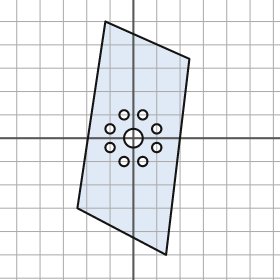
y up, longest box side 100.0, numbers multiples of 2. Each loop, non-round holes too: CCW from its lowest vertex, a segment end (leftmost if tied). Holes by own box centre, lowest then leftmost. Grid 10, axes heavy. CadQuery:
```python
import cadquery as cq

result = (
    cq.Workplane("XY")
    .moveTo(14.0, -50.0)
    .lineTo(24.0, 34.0)
    .lineTo(-12.0, 50.0)
    .lineTo(-24.0, -30.0)
    .close()
    .moveTo(-4.0, -10.0)
    .circle(2.0)
    .moveTo(4.0, -10.0)
    .circle(2.0)
    .moveTo(-10.0, -4.0)
    .circle(2.0)
    .moveTo(10.0, -4.0)
    .circle(2.0)
    .moveTo(0.0, 0.0)
    .circle(4.0)
    .moveTo(-10.0, 4.0)
    .circle(2.0)
    .moveTo(10.0, 4.0)
    .circle(2.0)
    .moveTo(-4.0, 10.0)
    .circle(2.0)
    .moveTo(4.0, 10.0)
    .circle(2.0)
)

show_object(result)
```